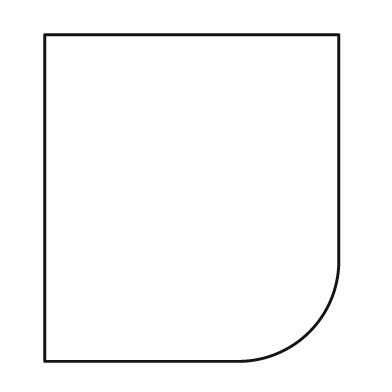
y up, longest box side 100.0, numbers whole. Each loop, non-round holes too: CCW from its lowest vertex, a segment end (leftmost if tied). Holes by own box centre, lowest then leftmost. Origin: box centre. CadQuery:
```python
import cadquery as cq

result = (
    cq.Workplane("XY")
    .moveTo(-45.0, -50.0)
    .lineTo(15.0, -50.0)
    .threePointArc((36.0, -41.0), (45.0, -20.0))
    .lineTo(45.0, 50.0)
    .lineTo(-45.0, 50.0)
    .close()
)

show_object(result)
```